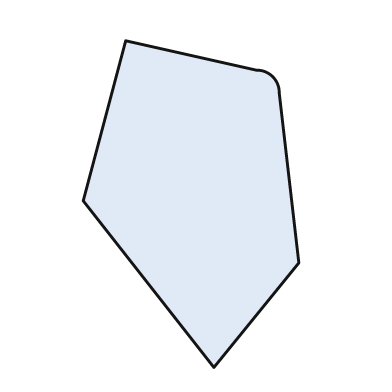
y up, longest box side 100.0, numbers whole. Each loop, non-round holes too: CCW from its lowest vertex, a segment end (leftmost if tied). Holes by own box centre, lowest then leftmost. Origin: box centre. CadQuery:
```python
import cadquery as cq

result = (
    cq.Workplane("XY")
    .moveTo(7.0, -50.0)
    .lineTo(33.0, -18.0)
    .lineTo(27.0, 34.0)
    .threePointArc((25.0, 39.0), (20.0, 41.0))
    .lineTo(-20.0, 50.0)
    .lineTo(-33.0, 1.0)
    .close()
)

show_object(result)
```